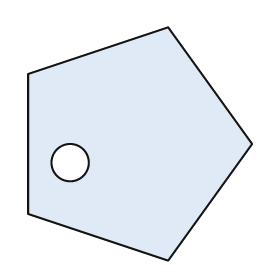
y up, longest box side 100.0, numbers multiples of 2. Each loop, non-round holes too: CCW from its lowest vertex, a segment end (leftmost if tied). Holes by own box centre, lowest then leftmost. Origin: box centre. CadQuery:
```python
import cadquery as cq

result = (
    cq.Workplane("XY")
    .moveTo(12.0, -50.0)
    .lineTo(48.0, 0.0)
    .lineTo(12.0, 50.0)
    .lineTo(-48.0, 30.0)
    .lineTo(-48.0, -30.0)
    .close()
    .moveTo(-30.0, -8.0)
    .circle(8.0)
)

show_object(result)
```